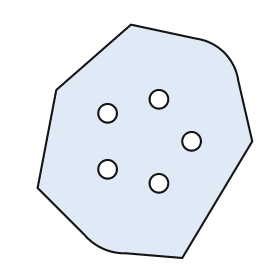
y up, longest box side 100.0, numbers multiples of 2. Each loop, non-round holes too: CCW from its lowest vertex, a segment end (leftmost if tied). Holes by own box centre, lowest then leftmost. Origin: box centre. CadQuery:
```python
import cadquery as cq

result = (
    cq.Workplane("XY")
    .moveTo(16.0, -50.0)
    .lineTo(46.0, 0.0)
    .lineTo(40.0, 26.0)
    .threePointArc((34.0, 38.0), (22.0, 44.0))
    .lineTo(-6.0, 50.0)
    .lineTo(-38.0, 22.0)
    .lineTo(-46.0, -20.0)
    .lineTo(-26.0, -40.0)
    .threePointArc((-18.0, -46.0), (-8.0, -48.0))
    .close()
    .moveTo(6.0, -18.0)
    .circle(4.0)
    .moveTo(-16.0, -12.0)
    .circle(4.0)
    .moveTo(20.0, 0.0)
    .circle(4.0)
    .moveTo(-16.0, 12.0)
    .circle(4.0)
    .moveTo(6.0, 18.0)
    .circle(4.0)
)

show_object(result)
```